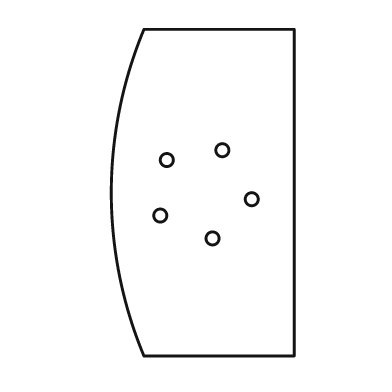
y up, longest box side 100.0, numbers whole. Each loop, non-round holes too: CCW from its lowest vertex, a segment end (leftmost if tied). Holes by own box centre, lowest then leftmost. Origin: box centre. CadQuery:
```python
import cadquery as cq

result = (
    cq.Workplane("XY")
    .moveTo(-18.0, -50.0)
    .lineTo(28.0, -50.0)
    .lineTo(28.0, 50.0)
    .lineTo(-18.0, 50.0)
    .threePointArc((-28.0, 0.0), (-18.0, -50.0))
    .close()
    .moveTo(3.0, -14.0)
    .circle(2.0)
    .moveTo(-13.0, -7.0)
    .circle(2.0)
    .moveTo(15.0, -2.0)
    .circle(2.0)
    .moveTo(-11.0, 10.0)
    .circle(2.0)
    .moveTo(6.0, 13.0)
    .circle(2.0)
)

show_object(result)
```